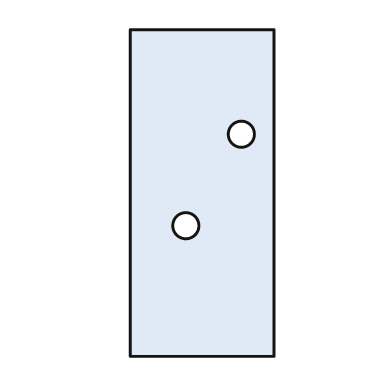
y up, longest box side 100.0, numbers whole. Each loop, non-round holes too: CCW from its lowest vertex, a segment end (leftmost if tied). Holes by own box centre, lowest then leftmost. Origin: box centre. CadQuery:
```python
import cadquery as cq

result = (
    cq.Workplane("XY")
    .moveTo(-22.0, -50.0)
    .lineTo(22.0, -50.0)
    .lineTo(22.0, 50.0)
    .lineTo(-22.0, 50.0)
    .close()
    .moveTo(-5.0, -10.0)
    .circle(4.0)
    .moveTo(12.0, 18.0)
    .circle(4.0)
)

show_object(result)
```